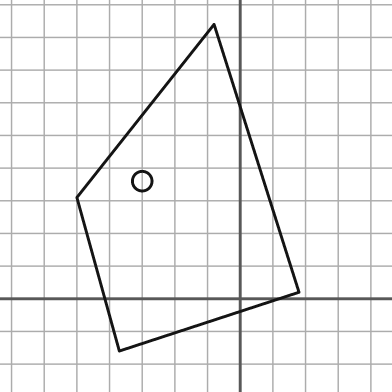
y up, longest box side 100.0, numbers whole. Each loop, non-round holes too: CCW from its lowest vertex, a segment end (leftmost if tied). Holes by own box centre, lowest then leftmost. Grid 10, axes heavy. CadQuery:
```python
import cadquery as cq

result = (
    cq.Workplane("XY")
    .moveTo(-37.0, -16.0)
    .lineTo(18.0, 2.0)
    .lineTo(-8.0, 84.0)
    .lineTo(-50.0, 31.0)
    .close()
    .moveTo(-30.0, 36.0)
    .circle(3.0)
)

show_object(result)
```